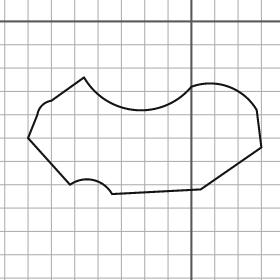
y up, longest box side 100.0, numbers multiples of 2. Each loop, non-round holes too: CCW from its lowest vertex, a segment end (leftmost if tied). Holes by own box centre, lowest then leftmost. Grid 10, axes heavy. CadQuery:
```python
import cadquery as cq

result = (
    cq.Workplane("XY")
    .moveTo(-34.0, -74.0)
    .lineTo(4.0, -72.0)
    .lineTo(30.0, -54.0)
    .lineTo(28.0, -38.0)
    .threePointArc((16.0, -28.0), (0.0, -28.0))
    .threePointArc((-24.0, -38.0), (-46.0, -24.0))
    .lineTo(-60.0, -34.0)
    .threePointArc((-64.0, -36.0), (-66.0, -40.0))
    .lineTo(-70.0, -50.0)
    .lineTo(-52.0, -70.0)
    .threePointArc((-42.0, -68.0), (-34.0, -74.0))
    .close()
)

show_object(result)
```